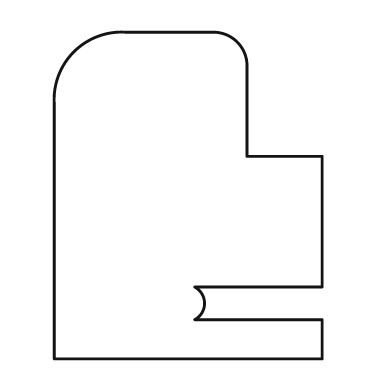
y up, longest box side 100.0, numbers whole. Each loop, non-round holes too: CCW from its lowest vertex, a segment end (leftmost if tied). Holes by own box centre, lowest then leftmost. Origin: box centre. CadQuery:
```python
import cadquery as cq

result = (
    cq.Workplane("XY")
    .moveTo(-41.0, -50.0)
    .lineTo(41.0, -50.0)
    .lineTo(41.0, -38.0)
    .lineTo(2.0, -38.0)
    .threePointArc((5.0, -33.0), (2.0, -28.0))
    .lineTo(41.0, -28.0)
    .lineTo(41.0, 12.0)
    .lineTo(18.0, 12.0)
    .lineTo(18.0, 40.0)
    .threePointArc((15.0, 47.0), (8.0, 50.0))
    .lineTo(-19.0, 50.0)
    .threePointArc((-35.0, 44.0), (-41.0, 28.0))
    .close()
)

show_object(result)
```